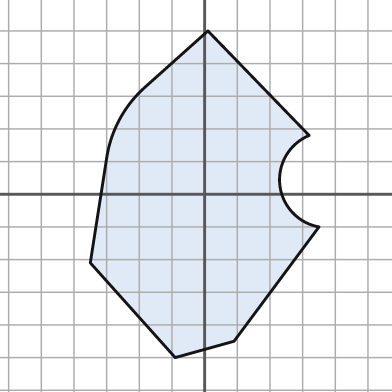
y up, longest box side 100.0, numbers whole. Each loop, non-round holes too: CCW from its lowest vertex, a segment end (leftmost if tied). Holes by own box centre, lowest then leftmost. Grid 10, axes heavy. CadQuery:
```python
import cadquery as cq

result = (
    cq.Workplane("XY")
    .moveTo(-9.0, -50.0)
    .lineTo(9.0, -45.0)
    .lineTo(35.0, -10.0)
    .threePointArc((23.0, 3.0), (32.0, 18.0))
    .lineTo(1.0, 50.0)
    .lineTo(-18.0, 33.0)
    .threePointArc((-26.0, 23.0), (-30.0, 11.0))
    .lineTo(-35.0, -21.0)
    .close()
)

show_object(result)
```